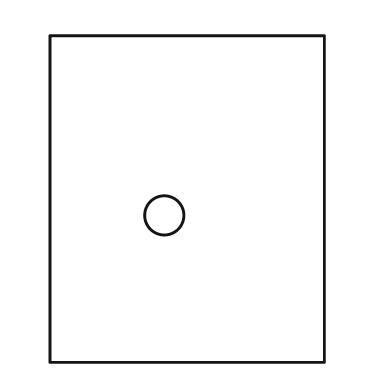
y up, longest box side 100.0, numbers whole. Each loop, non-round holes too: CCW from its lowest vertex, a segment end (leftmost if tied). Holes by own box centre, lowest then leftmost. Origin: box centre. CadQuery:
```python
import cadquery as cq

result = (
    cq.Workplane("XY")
    .moveTo(-42.0, -50.0)
    .lineTo(42.0, -50.0)
    .lineTo(42.0, 50.0)
    .lineTo(-42.0, 50.0)
    .close()
    .moveTo(-7.0, -5.0)
    .circle(6.0)
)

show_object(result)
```